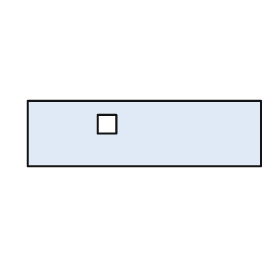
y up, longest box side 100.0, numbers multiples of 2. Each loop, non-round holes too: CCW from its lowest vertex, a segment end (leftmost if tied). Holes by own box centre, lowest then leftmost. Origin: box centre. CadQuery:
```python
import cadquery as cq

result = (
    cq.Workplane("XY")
    .moveTo(-50.0, -14.0)
    .lineTo(50.0, -14.0)
    .lineTo(50.0, 14.0)
    .lineTo(-50.0, 14.0)
    .close()
    .moveTo(-20.0, 0.0)
    .lineTo(-12.0, 0.0)
    .lineTo(-12.0, 8.0)
    .lineTo(-20.0, 8.0)
    .close()
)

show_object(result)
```